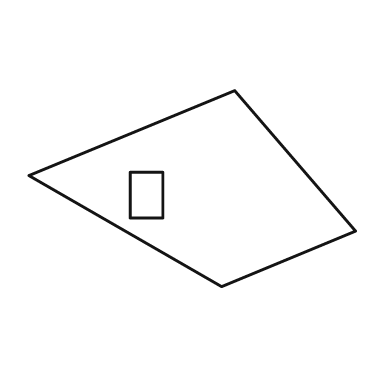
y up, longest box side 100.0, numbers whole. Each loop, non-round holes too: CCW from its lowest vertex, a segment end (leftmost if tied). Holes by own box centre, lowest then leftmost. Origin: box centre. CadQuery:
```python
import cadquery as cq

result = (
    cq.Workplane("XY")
    .moveTo(9.0, -30.0)
    .lineTo(50.0, -13.0)
    .lineTo(13.0, 30.0)
    .lineTo(-50.0, 4.0)
    .close()
    .moveTo(-19.0, -9.0)
    .lineTo(-9.0, -9.0)
    .lineTo(-9.0, 5.0)
    .lineTo(-19.0, 5.0)
    .close()
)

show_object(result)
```